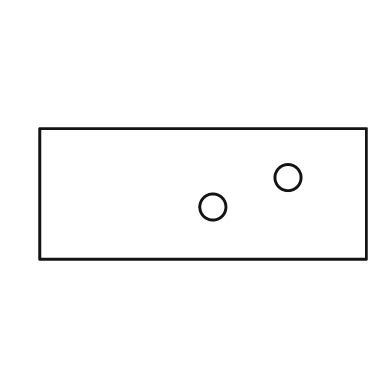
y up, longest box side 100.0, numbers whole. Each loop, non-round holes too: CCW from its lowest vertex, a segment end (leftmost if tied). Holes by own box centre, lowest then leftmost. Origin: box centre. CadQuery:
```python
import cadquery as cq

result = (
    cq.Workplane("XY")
    .moveTo(-50.0, -20.0)
    .lineTo(50.0, -20.0)
    .lineTo(50.0, 20.0)
    .lineTo(-50.0, 20.0)
    .close()
    .moveTo(3.0, -4.0)
    .circle(4.0)
    .moveTo(26.0, 5.0)
    .circle(4.0)
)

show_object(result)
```